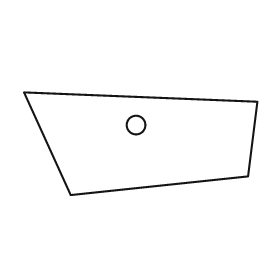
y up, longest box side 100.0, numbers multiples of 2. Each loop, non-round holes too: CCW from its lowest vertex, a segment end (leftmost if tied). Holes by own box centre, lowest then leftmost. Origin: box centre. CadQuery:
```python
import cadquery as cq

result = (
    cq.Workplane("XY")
    .moveTo(-30.0, -22.0)
    .lineTo(46.0, -14.0)
    .lineTo(50.0, 18.0)
    .lineTo(-50.0, 22.0)
    .close()
    .moveTo(-2.0, 8.0)
    .circle(4.0)
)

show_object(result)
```